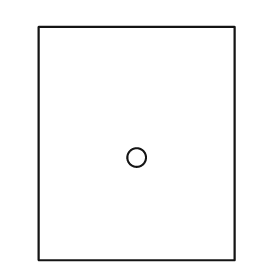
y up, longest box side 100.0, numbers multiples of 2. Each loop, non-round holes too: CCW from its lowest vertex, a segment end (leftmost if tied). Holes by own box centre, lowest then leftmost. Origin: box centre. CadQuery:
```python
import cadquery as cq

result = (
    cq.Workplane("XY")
    .moveTo(-42.0, -50.0)
    .lineTo(42.0, -50.0)
    .lineTo(42.0, 50.0)
    .lineTo(-42.0, 50.0)
    .close()
    .moveTo(0.0, -6.0)
    .circle(4.0)
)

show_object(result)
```